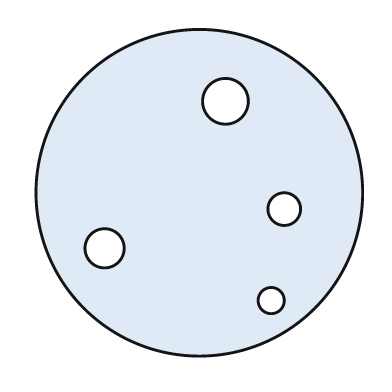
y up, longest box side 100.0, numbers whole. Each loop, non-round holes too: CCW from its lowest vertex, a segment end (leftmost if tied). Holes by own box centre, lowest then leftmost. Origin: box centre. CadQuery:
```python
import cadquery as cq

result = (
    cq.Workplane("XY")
    .moveTo(0.0, 0.0)
    .circle(50.0)
    .moveTo(22.0, -33.0)
    .circle(4.0)
    .moveTo(-29.0, -17.0)
    .circle(6.0)
    .moveTo(26.0, -5.0)
    .circle(5.0)
    .moveTo(8.0, 28.0)
    .circle(7.0)
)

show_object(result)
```